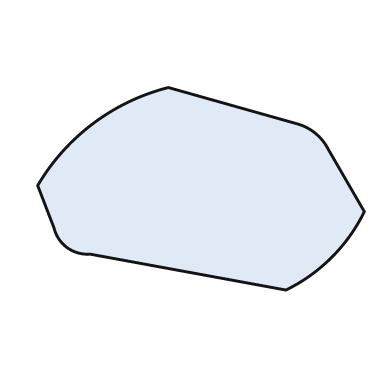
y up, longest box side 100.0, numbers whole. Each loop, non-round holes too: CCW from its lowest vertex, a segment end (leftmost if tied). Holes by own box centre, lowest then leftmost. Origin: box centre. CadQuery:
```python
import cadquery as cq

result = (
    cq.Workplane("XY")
    .moveTo(26.0, -31.0)
    .threePointArc((40.0, -21.0), (50.0, -7.0))
    .lineTo(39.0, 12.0)
    .threePointArc((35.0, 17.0), (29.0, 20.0))
    .lineTo(-10.0, 31.0)
    .threePointArc((-33.0, 20.0), (-50.0, 1.0))
    .lineTo(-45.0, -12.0)
    .threePointArc((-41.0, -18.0), (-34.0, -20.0))
    .close()
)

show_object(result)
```